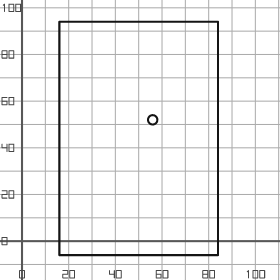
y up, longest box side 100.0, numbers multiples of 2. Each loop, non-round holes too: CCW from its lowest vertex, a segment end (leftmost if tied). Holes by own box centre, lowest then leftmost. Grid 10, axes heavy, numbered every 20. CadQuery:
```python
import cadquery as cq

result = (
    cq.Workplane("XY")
    .moveTo(16.0, -6.0)
    .lineTo(84.0, -6.0)
    .lineTo(84.0, 94.0)
    .lineTo(16.0, 94.0)
    .close()
    .moveTo(56.0, 52.0)
    .circle(2.0)
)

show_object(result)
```